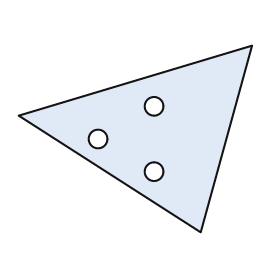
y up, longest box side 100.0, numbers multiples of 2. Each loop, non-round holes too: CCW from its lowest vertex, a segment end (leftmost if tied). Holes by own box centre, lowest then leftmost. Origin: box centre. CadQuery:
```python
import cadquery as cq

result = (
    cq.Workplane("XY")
    .moveTo(28.0, -40.0)
    .lineTo(50.0, 40.0)
    .lineTo(-50.0, 10.0)
    .close()
    .moveTo(8.0, -14.0)
    .circle(4.0)
    .moveTo(-16.0, 0.0)
    .circle(4.0)
    .moveTo(8.0, 14.0)
    .circle(4.0)
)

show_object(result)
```